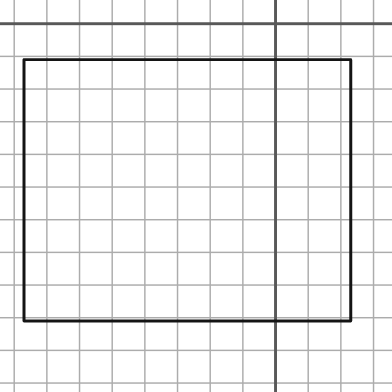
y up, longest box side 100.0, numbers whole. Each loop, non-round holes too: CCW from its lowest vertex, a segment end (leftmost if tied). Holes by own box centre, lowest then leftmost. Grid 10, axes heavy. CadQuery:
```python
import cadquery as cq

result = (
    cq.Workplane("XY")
    .moveTo(-77.0, -91.0)
    .lineTo(23.0, -91.0)
    .lineTo(23.0, -11.0)
    .lineTo(-77.0, -11.0)
    .close()
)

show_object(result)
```